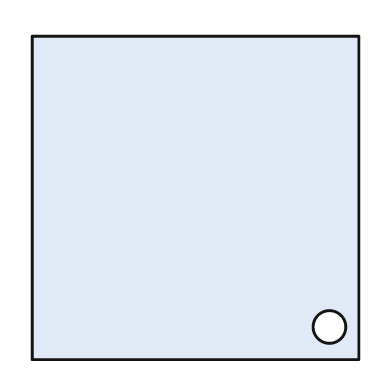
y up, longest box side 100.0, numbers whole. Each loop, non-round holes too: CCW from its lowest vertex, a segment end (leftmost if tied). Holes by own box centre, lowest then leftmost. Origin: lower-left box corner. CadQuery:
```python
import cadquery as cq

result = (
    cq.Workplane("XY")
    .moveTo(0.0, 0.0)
    .lineTo(100.0, 0.0)
    .lineTo(100.0, 99.0)
    .lineTo(0.0, 99.0)
    .close()
    .moveTo(91.0, 10.0)
    .circle(5.0)
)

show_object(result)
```